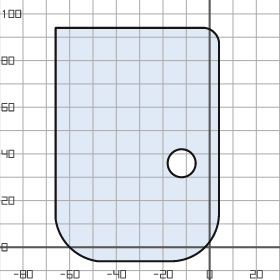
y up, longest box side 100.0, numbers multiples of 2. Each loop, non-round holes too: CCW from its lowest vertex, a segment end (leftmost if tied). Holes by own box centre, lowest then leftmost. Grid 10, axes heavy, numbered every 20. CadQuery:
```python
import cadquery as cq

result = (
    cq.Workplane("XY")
    .moveTo(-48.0, -6.0)
    .lineTo(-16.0, -6.0)
    .threePointArc((-2.0, 0.0), (4.0, 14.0))
    .lineTo(4.0, 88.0)
    .threePointArc((2.0, 92.0), (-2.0, 94.0))
    .lineTo(-66.0, 94.0)
    .lineTo(-66.0, 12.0)
    .threePointArc((-60.0, 0.0), (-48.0, -6.0))
    .close()
    .moveTo(-12.0, 36.0)
    .circle(6.0)
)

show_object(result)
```